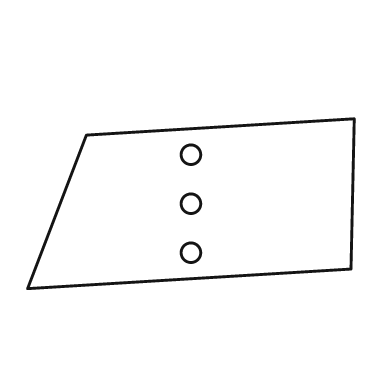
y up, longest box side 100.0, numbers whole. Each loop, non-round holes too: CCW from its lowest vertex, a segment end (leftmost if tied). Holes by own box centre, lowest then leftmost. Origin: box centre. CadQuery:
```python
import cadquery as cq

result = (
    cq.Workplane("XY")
    .moveTo(-50.0, -26.0)
    .lineTo(49.0, -20.0)
    .lineTo(50.0, 26.0)
    .lineTo(-32.0, 21.0)
    .close()
    .moveTo(0.0, -15.0)
    .circle(3.0)
    .moveTo(0.0, 0.0)
    .circle(3.0)
    .moveTo(0.0, 15.0)
    .circle(3.0)
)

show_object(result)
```